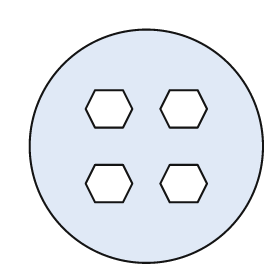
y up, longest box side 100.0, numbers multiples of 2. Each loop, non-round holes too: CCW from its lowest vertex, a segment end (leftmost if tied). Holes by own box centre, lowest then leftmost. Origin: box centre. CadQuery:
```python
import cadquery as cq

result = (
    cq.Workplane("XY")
    .moveTo(0.0, 0.0)
    .circle(50.0)
    .moveTo(-22.0, -24.0)
    .lineTo(-10.0, -24.0)
    .lineTo(-6.0, -16.0)
    .lineTo(-10.0, -8.0)
    .lineTo(-22.0, -8.0)
    .lineTo(-26.0, -16.0)
    .close()
    .moveTo(10.0, -24.0)
    .lineTo(22.0, -24.0)
    .lineTo(26.0, -16.0)
    .lineTo(22.0, -8.0)
    .lineTo(10.0, -8.0)
    .lineTo(6.0, -16.0)
    .close()
    .moveTo(-22.0, 8.0)
    .lineTo(-10.0, 8.0)
    .lineTo(-6.0, 16.0)
    .lineTo(-10.0, 24.0)
    .lineTo(-22.0, 24.0)
    .lineTo(-26.0, 16.0)
    .close()
    .moveTo(10.0, 8.0)
    .lineTo(22.0, 8.0)
    .lineTo(26.0, 16.0)
    .lineTo(22.0, 24.0)
    .lineTo(10.0, 24.0)
    .lineTo(6.0, 16.0)
    .close()
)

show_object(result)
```